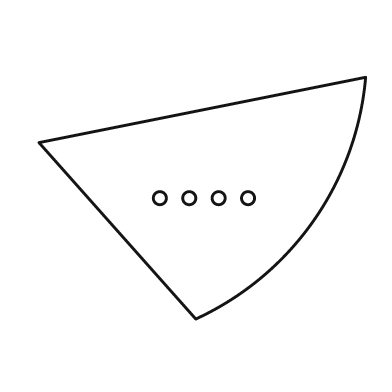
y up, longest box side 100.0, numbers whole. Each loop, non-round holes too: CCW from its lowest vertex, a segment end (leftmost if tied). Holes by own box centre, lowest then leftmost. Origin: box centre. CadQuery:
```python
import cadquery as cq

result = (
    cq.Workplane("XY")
    .moveTo(-2.0, -37.0)
    .threePointArc((34.0, -7.0), (50.0, 37.0))
    .lineTo(-50.0, 17.0)
    .close()
    .moveTo(-13.0, 0.0)
    .circle(2.0)
    .moveTo(-4.0, 0.0)
    .circle(2.0)
    .moveTo(5.0, 0.0)
    .circle(2.0)
    .moveTo(14.0, 0.0)
    .circle(2.0)
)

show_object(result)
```